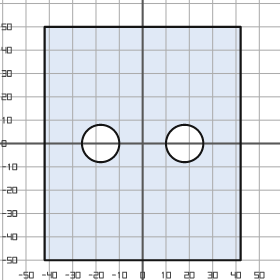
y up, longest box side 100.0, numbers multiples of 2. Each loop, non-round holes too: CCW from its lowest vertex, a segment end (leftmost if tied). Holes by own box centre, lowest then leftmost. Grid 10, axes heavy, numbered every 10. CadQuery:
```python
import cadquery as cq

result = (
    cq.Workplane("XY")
    .moveTo(-42.0, -50.0)
    .lineTo(42.0, -50.0)
    .lineTo(42.0, 50.0)
    .lineTo(-42.0, 50.0)
    .close()
    .moveTo(-18.0, 0.0)
    .circle(8.0)
    .moveTo(18.0, 0.0)
    .circle(8.0)
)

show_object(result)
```